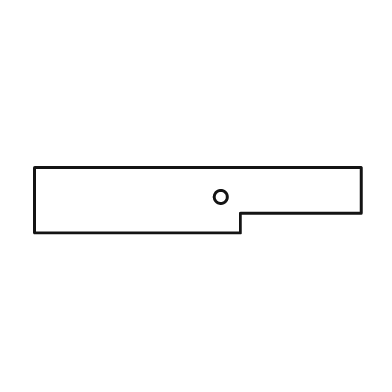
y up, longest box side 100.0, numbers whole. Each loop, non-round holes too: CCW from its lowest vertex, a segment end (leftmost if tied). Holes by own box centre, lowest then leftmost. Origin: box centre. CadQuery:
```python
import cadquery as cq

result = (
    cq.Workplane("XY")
    .moveTo(-50.0, -10.0)
    .lineTo(13.0, -10.0)
    .lineTo(13.0, -4.0)
    .lineTo(50.0, -4.0)
    .lineTo(50.0, 10.0)
    .lineTo(-50.0, 10.0)
    .close()
    .moveTo(7.0, 1.0)
    .circle(2.0)
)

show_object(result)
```